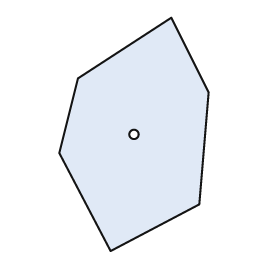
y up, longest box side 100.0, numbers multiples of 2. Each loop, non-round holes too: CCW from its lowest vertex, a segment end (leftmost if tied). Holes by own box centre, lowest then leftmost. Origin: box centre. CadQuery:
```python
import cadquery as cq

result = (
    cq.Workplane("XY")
    .moveTo(-10.0, -50.0)
    .lineTo(28.0, -30.0)
    .lineTo(32.0, 18.0)
    .lineTo(16.0, 50.0)
    .lineTo(-24.0, 24.0)
    .lineTo(-32.0, -8.0)
    .close()
    .moveTo(0.0, 0.0)
    .circle(2.0)
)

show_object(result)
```